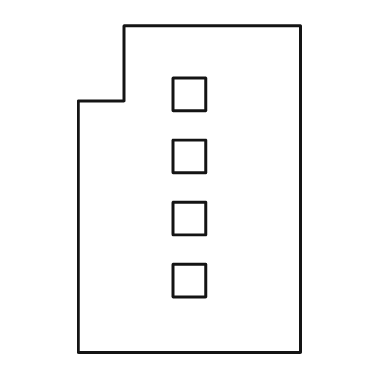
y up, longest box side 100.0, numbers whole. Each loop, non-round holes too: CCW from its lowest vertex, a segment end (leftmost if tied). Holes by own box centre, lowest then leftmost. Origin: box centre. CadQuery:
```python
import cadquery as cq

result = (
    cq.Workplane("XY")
    .moveTo(-34.0, -50.0)
    .lineTo(34.0, -50.0)
    .lineTo(34.0, 50.0)
    .lineTo(-20.0, 50.0)
    .lineTo(-20.0, 27.0)
    .lineTo(-34.0, 27.0)
    .close()
    .moveTo(-5.0, -33.0)
    .lineTo(5.0, -33.0)
    .lineTo(5.0, -23.0)
    .lineTo(-5.0, -23.0)
    .close()
    .moveTo(-5.0, -14.0)
    .lineTo(5.0, -14.0)
    .lineTo(5.0, -4.0)
    .lineTo(-5.0, -4.0)
    .close()
    .moveTo(-5.0, 5.0)
    .lineTo(5.0, 5.0)
    .lineTo(5.0, 15.0)
    .lineTo(-5.0, 15.0)
    .close()
    .moveTo(-5.0, 24.0)
    .lineTo(5.0, 24.0)
    .lineTo(5.0, 34.0)
    .lineTo(-5.0, 34.0)
    .close()
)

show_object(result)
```